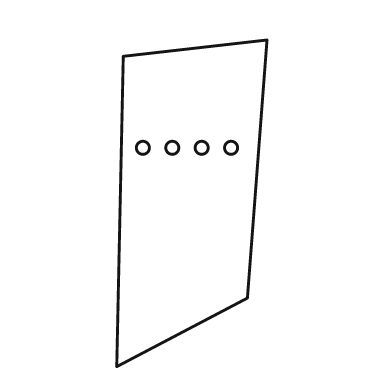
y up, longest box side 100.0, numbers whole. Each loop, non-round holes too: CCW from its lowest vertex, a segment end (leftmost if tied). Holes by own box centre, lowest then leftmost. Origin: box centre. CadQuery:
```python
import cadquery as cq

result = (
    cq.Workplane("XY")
    .moveTo(-23.0, -50.0)
    .lineTo(17.0, -29.0)
    .lineTo(23.0, 50.0)
    .lineTo(-21.0, 45.0)
    .close()
    .moveTo(-15.0, 17.0)
    .circle(2.0)
    .moveTo(-6.0, 17.0)
    .circle(2.0)
    .moveTo(3.0, 17.0)
    .circle(2.0)
    .moveTo(12.0, 17.0)
    .circle(2.0)
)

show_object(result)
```